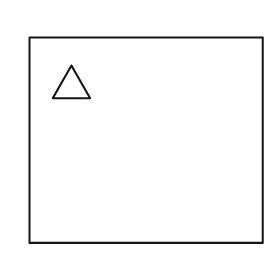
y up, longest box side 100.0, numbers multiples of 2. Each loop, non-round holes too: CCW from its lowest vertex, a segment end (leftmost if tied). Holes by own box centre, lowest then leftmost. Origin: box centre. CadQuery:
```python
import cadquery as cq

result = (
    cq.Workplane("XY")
    .moveTo(-50.0, -44.0)
    .lineTo(50.0, -44.0)
    .lineTo(50.0, 44.0)
    .lineTo(-50.0, 44.0)
    .close()
    .moveTo(-40.0, 18.0)
    .lineTo(-24.0, 18.0)
    .lineTo(-32.0, 32.0)
    .close()
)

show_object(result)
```